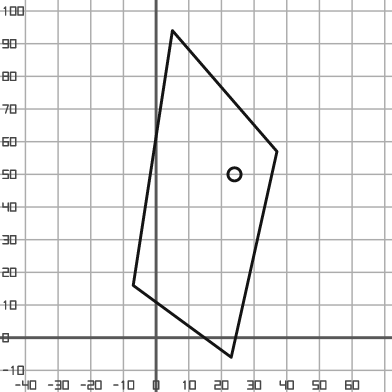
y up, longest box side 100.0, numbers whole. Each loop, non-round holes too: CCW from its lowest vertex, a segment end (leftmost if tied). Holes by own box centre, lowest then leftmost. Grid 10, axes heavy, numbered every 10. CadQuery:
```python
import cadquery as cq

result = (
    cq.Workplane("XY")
    .moveTo(23.0, -6.0)
    .lineTo(37.0, 57.0)
    .lineTo(5.0, 94.0)
    .lineTo(-7.0, 16.0)
    .close()
    .moveTo(24.0, 50.0)
    .circle(2.0)
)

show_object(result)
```